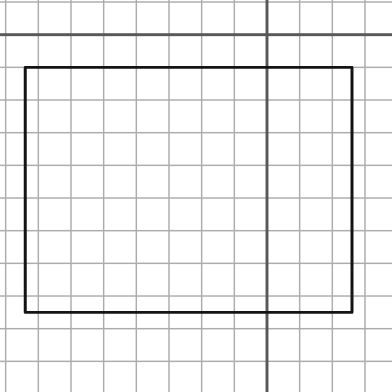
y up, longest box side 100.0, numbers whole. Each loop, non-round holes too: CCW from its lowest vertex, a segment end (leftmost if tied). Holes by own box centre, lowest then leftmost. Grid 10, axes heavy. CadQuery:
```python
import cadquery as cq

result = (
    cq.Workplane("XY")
    .moveTo(-74.0, -85.0)
    .lineTo(26.0, -85.0)
    .lineTo(26.0, -10.0)
    .lineTo(-74.0, -10.0)
    .close()
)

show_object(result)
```